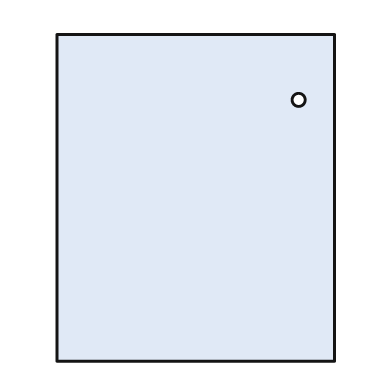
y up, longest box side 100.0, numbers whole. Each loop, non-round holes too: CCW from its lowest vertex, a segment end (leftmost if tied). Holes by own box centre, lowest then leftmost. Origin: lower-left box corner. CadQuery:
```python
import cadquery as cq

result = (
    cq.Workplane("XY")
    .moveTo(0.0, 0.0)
    .lineTo(85.0, 0.0)
    .lineTo(85.0, 100.0)
    .lineTo(0.0, 100.0)
    .close()
    .moveTo(74.0, 80.0)
    .circle(2.0)
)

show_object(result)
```